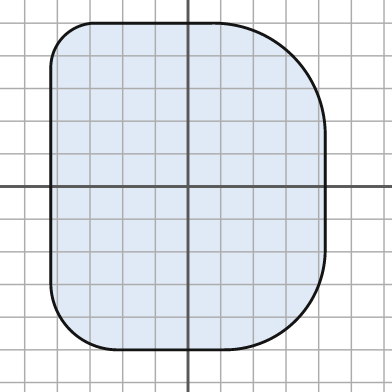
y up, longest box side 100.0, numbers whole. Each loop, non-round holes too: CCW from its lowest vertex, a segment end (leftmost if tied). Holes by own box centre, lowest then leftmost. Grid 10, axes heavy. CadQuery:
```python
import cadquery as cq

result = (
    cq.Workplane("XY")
    .moveTo(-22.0, -50.0)
    .lineTo(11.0, -50.0)
    .threePointArc((33.0, -41.0), (42.0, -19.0))
    .lineTo(42.0, 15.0)
    .threePointArc((32.0, 40.0), (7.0, 50.0))
    .lineTo(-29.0, 50.0)
    .threePointArc((-38.0, 46.0), (-42.0, 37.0))
    .lineTo(-42.0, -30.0)
    .threePointArc((-36.0, -44.0), (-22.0, -50.0))
    .close()
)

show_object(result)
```